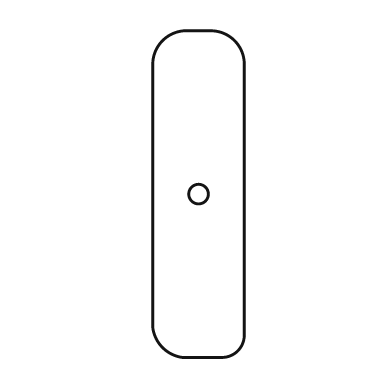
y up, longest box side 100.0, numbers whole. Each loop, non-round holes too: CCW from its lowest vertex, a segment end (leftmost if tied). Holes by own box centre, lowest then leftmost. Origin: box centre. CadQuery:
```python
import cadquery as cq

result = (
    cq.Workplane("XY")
    .moveTo(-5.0, -50.0)
    .lineTo(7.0, -50.0)
    .threePointArc((12.0, -48.0), (14.0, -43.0))
    .lineTo(14.0, 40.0)
    .threePointArc((11.0, 47.0), (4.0, 50.0))
    .lineTo(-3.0, 50.0)
    .threePointArc((-11.0, 47.0), (-14.0, 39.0))
    .lineTo(-14.0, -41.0)
    .threePointArc((-11.0, -47.0), (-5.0, -50.0))
    .close()
    .moveTo(0.0, 0.0)
    .circle(3.0)
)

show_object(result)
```